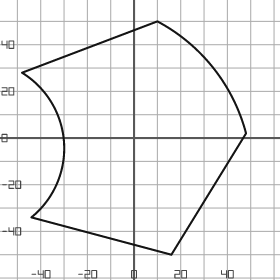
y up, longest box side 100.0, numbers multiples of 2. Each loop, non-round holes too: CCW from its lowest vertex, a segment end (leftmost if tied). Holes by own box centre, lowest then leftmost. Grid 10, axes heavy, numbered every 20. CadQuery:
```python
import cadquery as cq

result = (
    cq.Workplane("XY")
    .moveTo(16.0, -50.0)
    .lineTo(48.0, 2.0)
    .threePointArc((34.0, 30.0), (10.0, 50.0))
    .lineTo(-48.0, 28.0)
    .threePointArc((-30.0, -2.0), (-44.0, -34.0))
    .close()
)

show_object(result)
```